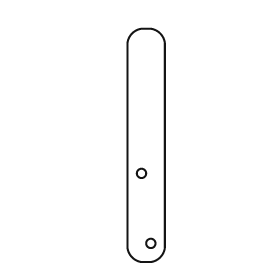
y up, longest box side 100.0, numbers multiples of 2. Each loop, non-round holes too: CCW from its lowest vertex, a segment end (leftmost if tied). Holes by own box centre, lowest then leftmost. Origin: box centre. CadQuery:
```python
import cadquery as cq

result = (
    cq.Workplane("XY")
    .moveTo(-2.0, -50.0)
    .lineTo(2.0, -50.0)
    .threePointArc((6.0, -48.0), (8.0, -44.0))
    .lineTo(8.0, 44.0)
    .threePointArc((6.0, 48.0), (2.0, 50.0))
    .lineTo(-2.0, 50.0)
    .threePointArc((-6.0, 48.0), (-8.0, 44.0))
    .lineTo(-8.0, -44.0)
    .threePointArc((-6.0, -48.0), (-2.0, -50.0))
    .close()
    .moveTo(2.0, -42.0)
    .circle(2.0)
    .moveTo(-2.0, -12.0)
    .circle(2.0)
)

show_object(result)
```